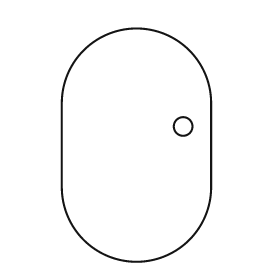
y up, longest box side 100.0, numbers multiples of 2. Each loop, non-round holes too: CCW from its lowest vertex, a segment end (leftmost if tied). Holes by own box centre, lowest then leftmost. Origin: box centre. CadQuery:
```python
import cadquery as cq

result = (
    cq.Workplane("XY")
    .moveTo(-32.0, -18.0)
    .threePointArc((0.0, -50.0), (32.0, -18.0))
    .lineTo(32.0, 18.0)
    .threePointArc((0.0, 50.0), (-32.0, 18.0))
    .close()
    .moveTo(20.0, 8.0)
    .circle(4.0)
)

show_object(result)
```